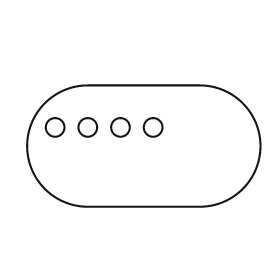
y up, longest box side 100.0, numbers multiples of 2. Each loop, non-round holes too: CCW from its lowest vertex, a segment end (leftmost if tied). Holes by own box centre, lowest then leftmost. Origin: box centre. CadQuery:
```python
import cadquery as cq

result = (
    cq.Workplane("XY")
    .moveTo(-24.0, -26.0)
    .lineTo(24.0, -26.0)
    .threePointArc((50.0, 0.0), (24.0, 26.0))
    .lineTo(-24.0, 26.0)
    .threePointArc((-50.0, 0.0), (-24.0, -26.0))
    .close()
    .moveTo(-38.0, 8.0)
    .circle(4.0)
    .moveTo(-24.0, 8.0)
    .circle(4.0)
    .moveTo(-10.0, 8.0)
    .circle(4.0)
    .moveTo(4.0, 8.0)
    .circle(4.0)
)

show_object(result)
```